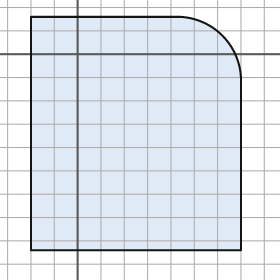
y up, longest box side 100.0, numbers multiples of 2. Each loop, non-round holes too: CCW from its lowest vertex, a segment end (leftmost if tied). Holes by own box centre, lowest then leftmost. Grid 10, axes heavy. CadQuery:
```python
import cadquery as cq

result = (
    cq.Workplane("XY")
    .moveTo(-20.0, -84.0)
    .lineTo(70.0, -84.0)
    .lineTo(70.0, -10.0)
    .threePointArc((62.0, 8.0), (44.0, 16.0))
    .lineTo(-20.0, 16.0)
    .close()
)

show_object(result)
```